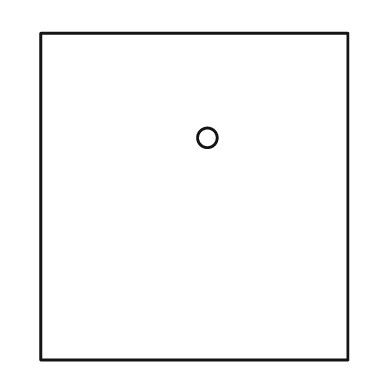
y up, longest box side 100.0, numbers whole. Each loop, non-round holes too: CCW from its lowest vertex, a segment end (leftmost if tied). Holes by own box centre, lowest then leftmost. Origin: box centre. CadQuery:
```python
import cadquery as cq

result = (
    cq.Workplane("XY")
    .moveTo(-47.0, -50.0)
    .lineTo(47.0, -50.0)
    .lineTo(47.0, 50.0)
    .lineTo(-47.0, 50.0)
    .close()
    .moveTo(4.0, 18.0)
    .circle(3.0)
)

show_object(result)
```